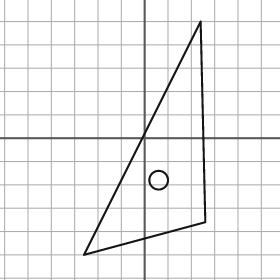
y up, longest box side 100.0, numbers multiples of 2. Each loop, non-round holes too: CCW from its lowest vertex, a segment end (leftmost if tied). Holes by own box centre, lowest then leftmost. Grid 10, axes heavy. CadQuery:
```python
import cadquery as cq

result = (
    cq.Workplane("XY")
    .moveTo(-26.0, -50.0)
    .lineTo(26.0, -36.0)
    .lineTo(24.0, 50.0)
    .close()
    .moveTo(6.0, -18.0)
    .circle(4.0)
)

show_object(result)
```